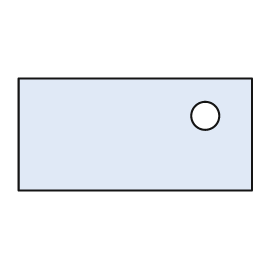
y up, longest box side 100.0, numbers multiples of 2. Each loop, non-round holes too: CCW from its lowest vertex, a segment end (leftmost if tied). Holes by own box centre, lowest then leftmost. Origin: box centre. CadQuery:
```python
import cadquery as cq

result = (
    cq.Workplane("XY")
    .moveTo(-50.0, -24.0)
    .lineTo(50.0, -24.0)
    .lineTo(50.0, 24.0)
    .lineTo(-50.0, 24.0)
    .close()
    .moveTo(30.0, 8.0)
    .circle(6.0)
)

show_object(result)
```